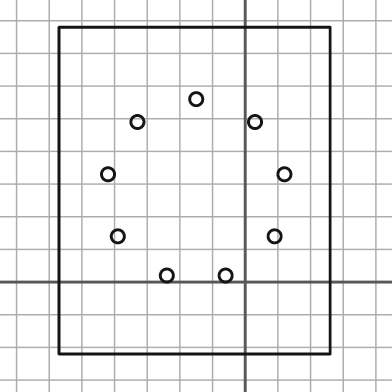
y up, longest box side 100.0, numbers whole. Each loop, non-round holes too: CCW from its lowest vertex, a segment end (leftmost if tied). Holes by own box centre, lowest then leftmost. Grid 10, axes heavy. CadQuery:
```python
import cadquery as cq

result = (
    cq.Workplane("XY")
    .moveTo(-57.0, -22.0)
    .lineTo(26.0, -22.0)
    .lineTo(26.0, 78.0)
    .lineTo(-57.0, 78.0)
    .close()
    .moveTo(-24.0, 2.0)
    .circle(2.0)
    .moveTo(-6.0, 2.0)
    .circle(2.0)
    .moveTo(-39.0, 14.0)
    .circle(2.0)
    .moveTo(9.0, 14.0)
    .circle(2.0)
    .moveTo(-42.0, 33.0)
    .circle(2.0)
    .moveTo(12.0, 33.0)
    .circle(2.0)
    .moveTo(-33.0, 49.0)
    .circle(2.0)
    .moveTo(3.0, 49.0)
    .circle(2.0)
    .moveTo(-15.0, 56.0)
    .circle(2.0)
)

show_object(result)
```